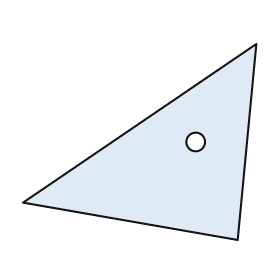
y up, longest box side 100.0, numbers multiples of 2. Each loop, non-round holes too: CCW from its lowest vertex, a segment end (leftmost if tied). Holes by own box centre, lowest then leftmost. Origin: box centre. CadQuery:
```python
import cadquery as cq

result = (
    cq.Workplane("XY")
    .moveTo(42.0, -42.0)
    .lineTo(50.0, 42.0)
    .lineTo(-50.0, -26.0)
    .close()
    .moveTo(24.0, 0.0)
    .circle(4.0)
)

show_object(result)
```